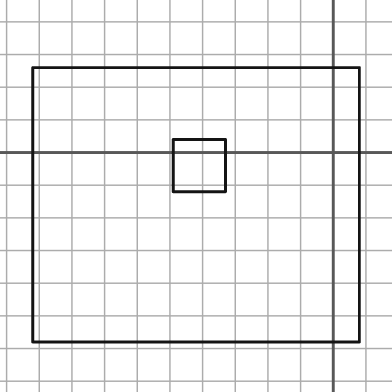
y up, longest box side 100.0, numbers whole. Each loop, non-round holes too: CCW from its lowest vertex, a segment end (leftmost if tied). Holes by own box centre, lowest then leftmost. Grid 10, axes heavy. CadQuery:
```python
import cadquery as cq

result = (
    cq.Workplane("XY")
    .moveTo(-92.0, -58.0)
    .lineTo(8.0, -58.0)
    .lineTo(8.0, 26.0)
    .lineTo(-92.0, 26.0)
    .close()
    .moveTo(-49.0, -12.0)
    .lineTo(-33.0, -12.0)
    .lineTo(-33.0, 4.0)
    .lineTo(-49.0, 4.0)
    .close()
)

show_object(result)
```